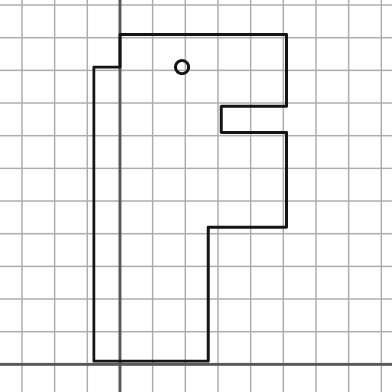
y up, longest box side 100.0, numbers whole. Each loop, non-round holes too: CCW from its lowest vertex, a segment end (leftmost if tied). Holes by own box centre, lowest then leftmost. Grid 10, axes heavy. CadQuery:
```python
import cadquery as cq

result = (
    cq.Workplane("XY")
    .moveTo(-8.0, 1.0)
    .lineTo(27.0, 1.0)
    .lineTo(27.0, 42.0)
    .lineTo(51.0, 42.0)
    .lineTo(51.0, 71.0)
    .lineTo(31.0, 71.0)
    .lineTo(31.0, 79.0)
    .lineTo(51.0, 79.0)
    .lineTo(51.0, 101.0)
    .lineTo(0.0, 101.0)
    .lineTo(0.0, 91.0)
    .lineTo(-8.0, 91.0)
    .close()
    .moveTo(19.0, 91.0)
    .circle(2.0)
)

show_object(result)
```